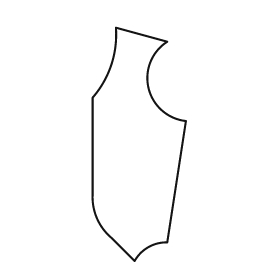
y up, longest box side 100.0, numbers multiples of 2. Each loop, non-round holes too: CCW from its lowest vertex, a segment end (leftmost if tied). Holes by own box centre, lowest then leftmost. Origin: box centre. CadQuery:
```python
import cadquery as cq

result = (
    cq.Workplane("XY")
    .moveTo(-2.0, -50.0)
    .threePointArc((4.0, -44.0), (12.0, -42.0))
    .lineTo(20.0, 10.0)
    .threePointArc((4.0, 24.0), (12.0, 44.0))
    .lineTo(-10.0, 50.0)
    .threePointArc((-12.0, 34.0), (-20.0, 20.0))
    .lineTo(-20.0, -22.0)
    .threePointArc((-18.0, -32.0), (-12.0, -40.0))
    .close()
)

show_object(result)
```